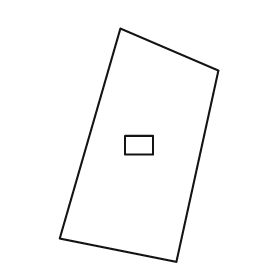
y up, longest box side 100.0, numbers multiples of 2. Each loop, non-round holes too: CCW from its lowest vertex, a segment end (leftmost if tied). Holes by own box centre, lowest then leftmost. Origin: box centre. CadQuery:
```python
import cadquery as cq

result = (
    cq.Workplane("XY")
    .moveTo(16.0, -50.0)
    .lineTo(34.0, 32.0)
    .lineTo(-8.0, 50.0)
    .lineTo(-34.0, -40.0)
    .close()
    .moveTo(-6.0, -4.0)
    .lineTo(6.0, -4.0)
    .lineTo(6.0, 4.0)
    .lineTo(-6.0, 4.0)
    .close()
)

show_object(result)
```